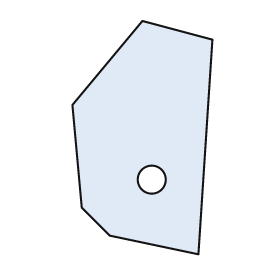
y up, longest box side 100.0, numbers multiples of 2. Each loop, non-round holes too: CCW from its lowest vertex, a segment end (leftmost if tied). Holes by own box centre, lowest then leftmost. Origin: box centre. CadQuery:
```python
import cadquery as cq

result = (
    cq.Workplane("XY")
    .moveTo(24.0, -50.0)
    .lineTo(30.0, 42.0)
    .lineTo(0.0, 50.0)
    .lineTo(-30.0, 14.0)
    .lineTo(-26.0, -30.0)
    .lineTo(-14.0, -42.0)
    .close()
    .moveTo(4.0, -18.0)
    .circle(6.0)
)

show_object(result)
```